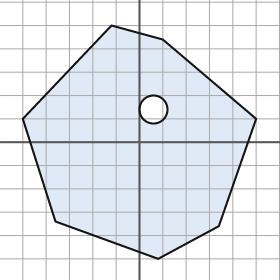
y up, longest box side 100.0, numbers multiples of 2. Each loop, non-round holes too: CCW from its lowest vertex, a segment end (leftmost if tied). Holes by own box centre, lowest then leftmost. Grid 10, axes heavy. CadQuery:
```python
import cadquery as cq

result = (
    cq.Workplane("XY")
    .moveTo(8.0, -50.0)
    .lineTo(34.0, -36.0)
    .lineTo(50.0, 10.0)
    .lineTo(10.0, 44.0)
    .lineTo(-12.0, 50.0)
    .lineTo(-50.0, 10.0)
    .lineTo(-36.0, -34.0)
    .close()
    .moveTo(6.0, 14.0)
    .circle(6.0)
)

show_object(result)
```